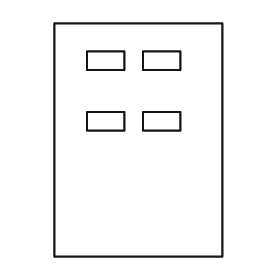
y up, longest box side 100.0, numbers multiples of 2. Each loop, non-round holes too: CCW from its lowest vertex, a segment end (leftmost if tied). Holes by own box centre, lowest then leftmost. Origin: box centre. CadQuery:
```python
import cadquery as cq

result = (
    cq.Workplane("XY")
    .moveTo(-36.0, -50.0)
    .lineTo(36.0, -50.0)
    .lineTo(36.0, 50.0)
    .lineTo(-36.0, 50.0)
    .close()
    .moveTo(-22.0, 4.0)
    .lineTo(-6.0, 4.0)
    .lineTo(-6.0, 12.0)
    .lineTo(-22.0, 12.0)
    .close()
    .moveTo(2.0, 4.0)
    .lineTo(18.0, 4.0)
    .lineTo(18.0, 12.0)
    .lineTo(2.0, 12.0)
    .close()
    .moveTo(-22.0, 30.0)
    .lineTo(-6.0, 30.0)
    .lineTo(-6.0, 38.0)
    .lineTo(-22.0, 38.0)
    .close()
    .moveTo(2.0, 30.0)
    .lineTo(18.0, 30.0)
    .lineTo(18.0, 38.0)
    .lineTo(2.0, 38.0)
    .close()
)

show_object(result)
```